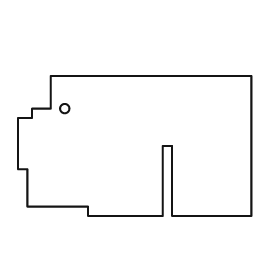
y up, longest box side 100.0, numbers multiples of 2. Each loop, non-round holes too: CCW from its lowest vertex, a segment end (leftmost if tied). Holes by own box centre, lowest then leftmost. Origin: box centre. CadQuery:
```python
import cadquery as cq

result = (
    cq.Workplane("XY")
    .moveTo(-20.0, -30.0)
    .lineTo(12.0, -30.0)
    .lineTo(12.0, 0.0)
    .lineTo(16.0, 0.0)
    .lineTo(16.0, -30.0)
    .lineTo(50.0, -30.0)
    .lineTo(50.0, 30.0)
    .lineTo(-36.0, 30.0)
    .lineTo(-36.0, 16.0)
    .lineTo(-44.0, 16.0)
    .lineTo(-44.0, 12.0)
    .lineTo(-50.0, 12.0)
    .lineTo(-50.0, -10.0)
    .lineTo(-46.0, -10.0)
    .lineTo(-46.0, -26.0)
    .lineTo(-20.0, -26.0)
    .close()
    .moveTo(-30.0, 16.0)
    .circle(2.0)
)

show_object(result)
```